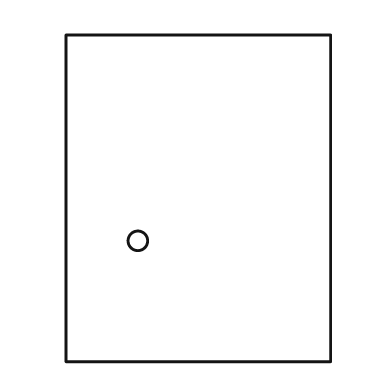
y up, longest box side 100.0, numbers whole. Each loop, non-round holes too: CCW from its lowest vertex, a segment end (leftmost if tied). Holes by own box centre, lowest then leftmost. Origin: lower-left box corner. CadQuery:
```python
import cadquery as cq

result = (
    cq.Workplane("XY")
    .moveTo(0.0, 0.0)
    .lineTo(81.0, 0.0)
    .lineTo(81.0, 100.0)
    .lineTo(0.0, 100.0)
    .close()
    .moveTo(22.0, 37.0)
    .circle(3.0)
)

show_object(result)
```